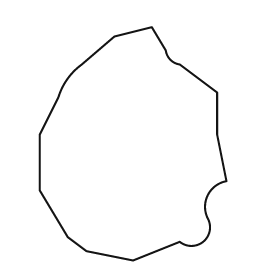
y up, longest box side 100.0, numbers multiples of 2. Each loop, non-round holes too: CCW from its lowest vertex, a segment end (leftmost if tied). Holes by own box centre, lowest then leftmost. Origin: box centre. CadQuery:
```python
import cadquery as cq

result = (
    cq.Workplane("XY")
    .moveTo(0.0, -50.0)
    .lineTo(20.0, -42.0)
    .threePointArc((30.0, -42.0), (32.0, -32.0))
    .threePointArc((32.0, -22.0), (40.0, -16.0))
    .lineTo(36.0, 4.0)
    .lineTo(36.0, 22.0)
    .lineTo(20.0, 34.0)
    .threePointArc((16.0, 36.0), (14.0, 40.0))
    .lineTo(8.0, 50.0)
    .lineTo(-8.0, 46.0)
    .lineTo(-22.0, 34.0)
    .threePointArc((-28.0, 28.0), (-32.0, 20.0))
    .lineTo(-40.0, 4.0)
    .lineTo(-40.0, -20.0)
    .lineTo(-28.0, -40.0)
    .lineTo(-20.0, -46.0)
    .close()
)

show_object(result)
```